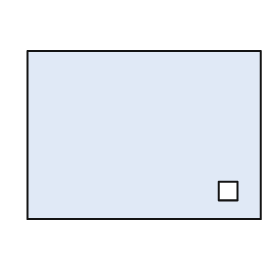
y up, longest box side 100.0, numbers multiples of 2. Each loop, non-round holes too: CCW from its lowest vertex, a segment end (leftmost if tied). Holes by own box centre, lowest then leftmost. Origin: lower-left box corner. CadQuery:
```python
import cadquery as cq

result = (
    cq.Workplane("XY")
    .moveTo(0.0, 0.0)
    .lineTo(100.0, 0.0)
    .lineTo(100.0, 72.0)
    .lineTo(0.0, 72.0)
    .close()
    .moveTo(82.0, 8.0)
    .lineTo(90.0, 8.0)
    .lineTo(90.0, 16.0)
    .lineTo(82.0, 16.0)
    .close()
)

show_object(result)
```